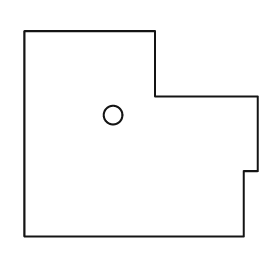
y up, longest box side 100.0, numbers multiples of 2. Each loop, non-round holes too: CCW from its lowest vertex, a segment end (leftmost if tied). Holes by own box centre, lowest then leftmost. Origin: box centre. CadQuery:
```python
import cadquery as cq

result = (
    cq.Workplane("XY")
    .moveTo(-50.0, -44.0)
    .lineTo(44.0, -44.0)
    .lineTo(44.0, -16.0)
    .lineTo(50.0, -16.0)
    .lineTo(50.0, 16.0)
    .lineTo(6.0, 16.0)
    .lineTo(6.0, 44.0)
    .lineTo(-50.0, 44.0)
    .close()
    .moveTo(-12.0, 8.0)
    .circle(4.0)
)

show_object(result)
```